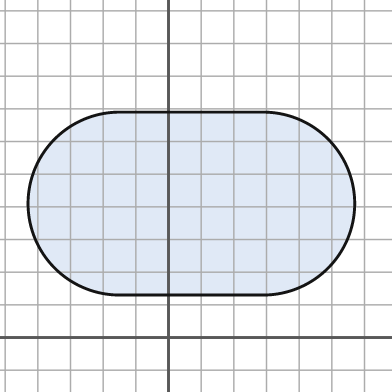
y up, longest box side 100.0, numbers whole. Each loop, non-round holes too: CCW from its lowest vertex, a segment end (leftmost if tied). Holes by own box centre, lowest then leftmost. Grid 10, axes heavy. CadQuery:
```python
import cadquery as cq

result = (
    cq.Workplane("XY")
    .moveTo(-15.0, 13.0)
    .lineTo(29.0, 13.0)
    .threePointArc((57.0, 41.0), (29.0, 69.0))
    .lineTo(-15.0, 69.0)
    .threePointArc((-43.0, 41.0), (-15.0, 13.0))
    .close()
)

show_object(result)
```